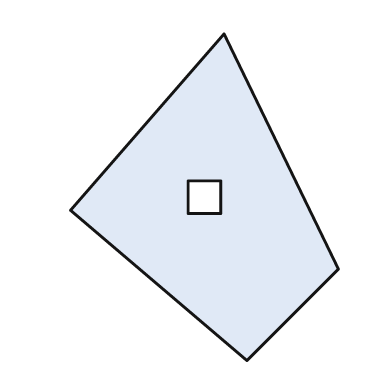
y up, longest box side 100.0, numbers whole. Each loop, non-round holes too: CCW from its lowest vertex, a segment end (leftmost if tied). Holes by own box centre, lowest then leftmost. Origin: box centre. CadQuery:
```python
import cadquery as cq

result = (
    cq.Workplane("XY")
    .moveTo(13.0, -50.0)
    .lineTo(41.0, -22.0)
    .lineTo(6.0, 50.0)
    .lineTo(-41.0, -4.0)
    .close()
    .moveTo(-5.0, -5.0)
    .lineTo(5.0, -5.0)
    .lineTo(5.0, 5.0)
    .lineTo(-5.0, 5.0)
    .close()
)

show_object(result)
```